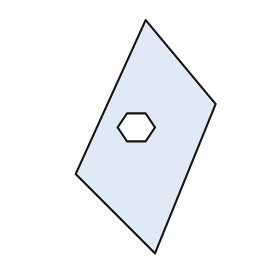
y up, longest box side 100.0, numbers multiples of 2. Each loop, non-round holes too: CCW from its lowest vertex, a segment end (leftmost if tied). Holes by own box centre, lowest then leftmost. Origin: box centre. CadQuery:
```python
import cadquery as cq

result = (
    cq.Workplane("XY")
    .moveTo(4.0, -50.0)
    .lineTo(30.0, 14.0)
    .lineTo(0.0, 50.0)
    .lineTo(-30.0, -16.0)
    .close()
    .moveTo(-8.0, -2.0)
    .lineTo(0.0, -2.0)
    .lineTo(4.0, 4.0)
    .lineTo(0.0, 10.0)
    .lineTo(-8.0, 10.0)
    .lineTo(-12.0, 4.0)
    .close()
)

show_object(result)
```